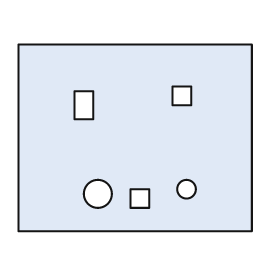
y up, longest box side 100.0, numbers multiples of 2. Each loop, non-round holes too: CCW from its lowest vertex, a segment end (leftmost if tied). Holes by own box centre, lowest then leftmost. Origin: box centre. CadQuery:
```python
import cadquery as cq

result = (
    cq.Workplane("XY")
    .moveTo(-50.0, -40.0)
    .lineTo(50.0, -40.0)
    .lineTo(50.0, 40.0)
    .lineTo(-50.0, 40.0)
    .close()
    .moveTo(-2.0, -30.0)
    .lineTo(6.0, -30.0)
    .lineTo(6.0, -22.0)
    .lineTo(-2.0, -22.0)
    .close()
    .moveTo(-16.0, -24.0)
    .circle(6.0)
    .moveTo(22.0, -22.0)
    .circle(4.0)
    .moveTo(-26.0, 8.0)
    .lineTo(-18.0, 8.0)
    .lineTo(-18.0, 20.0)
    .lineTo(-26.0, 20.0)
    .close()
    .moveTo(16.0, 14.0)
    .lineTo(24.0, 14.0)
    .lineTo(24.0, 22.0)
    .lineTo(16.0, 22.0)
    .close()
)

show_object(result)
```